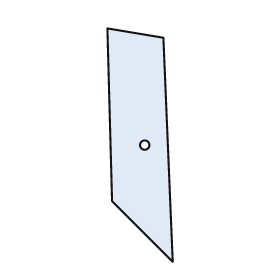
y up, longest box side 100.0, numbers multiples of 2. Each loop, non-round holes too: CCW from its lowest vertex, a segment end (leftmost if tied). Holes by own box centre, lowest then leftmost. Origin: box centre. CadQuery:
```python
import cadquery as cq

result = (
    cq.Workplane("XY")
    .moveTo(14.0, -50.0)
    .lineTo(10.0, 46.0)
    .lineTo(-14.0, 50.0)
    .lineTo(-12.0, -24.0)
    .close()
    .moveTo(2.0, 0.0)
    .circle(2.0)
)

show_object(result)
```